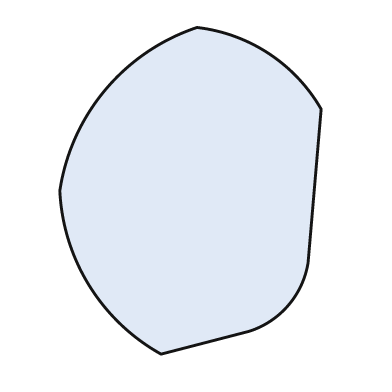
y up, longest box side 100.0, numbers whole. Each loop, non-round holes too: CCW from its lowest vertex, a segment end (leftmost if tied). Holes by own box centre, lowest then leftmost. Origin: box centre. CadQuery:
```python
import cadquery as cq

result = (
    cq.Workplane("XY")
    .moveTo(-9.0, -50.0)
    .lineTo(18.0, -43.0)
    .threePointArc((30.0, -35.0), (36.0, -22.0))
    .lineTo(40.0, 25.0)
    .threePointArc((24.0, 42.0), (2.0, 50.0))
    .threePointArc((-26.0, 31.0), (-40.0, 0.0))
    .threePointArc((-31.0, -29.0), (-9.0, -50.0))
    .close()
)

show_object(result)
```